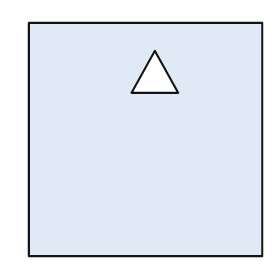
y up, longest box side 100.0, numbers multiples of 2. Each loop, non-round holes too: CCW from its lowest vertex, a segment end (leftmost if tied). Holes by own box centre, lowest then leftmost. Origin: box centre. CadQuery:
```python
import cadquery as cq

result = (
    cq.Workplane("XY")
    .moveTo(-50.0, -50.0)
    .lineTo(50.0, -50.0)
    .lineTo(50.0, 50.0)
    .lineTo(-50.0, 50.0)
    .close()
    .moveTo(-6.0, 20.0)
    .lineTo(14.0, 20.0)
    .lineTo(4.0, 38.0)
    .close()
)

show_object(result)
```